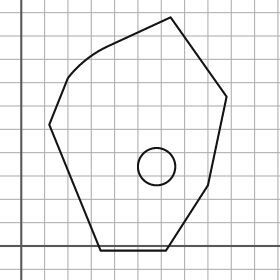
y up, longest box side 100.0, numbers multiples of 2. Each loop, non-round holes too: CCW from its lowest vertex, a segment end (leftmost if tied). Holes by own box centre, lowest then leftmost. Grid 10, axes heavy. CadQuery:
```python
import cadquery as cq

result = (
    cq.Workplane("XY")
    .moveTo(34.0, -2.0)
    .lineTo(62.0, -2.0)
    .lineTo(80.0, 26.0)
    .lineTo(88.0, 64.0)
    .lineTo(64.0, 98.0)
    .lineTo(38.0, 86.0)
    .threePointArc((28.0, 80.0), (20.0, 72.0))
    .lineTo(12.0, 52.0)
    .close()
    .moveTo(58.0, 34.0)
    .circle(8.0)
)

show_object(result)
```